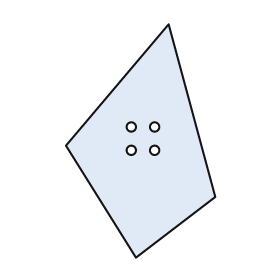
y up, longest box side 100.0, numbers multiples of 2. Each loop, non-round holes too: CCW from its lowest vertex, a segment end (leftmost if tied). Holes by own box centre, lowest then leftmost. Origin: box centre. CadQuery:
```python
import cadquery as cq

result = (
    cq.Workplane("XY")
    .moveTo(-2.0, -50.0)
    .lineTo(32.0, -24.0)
    .lineTo(12.0, 50.0)
    .lineTo(-32.0, -2.0)
    .close()
    .moveTo(-4.0, -4.0)
    .circle(2.0)
    .moveTo(6.0, -4.0)
    .circle(2.0)
    .moveTo(-4.0, 6.0)
    .circle(2.0)
    .moveTo(6.0, 6.0)
    .circle(2.0)
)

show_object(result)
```